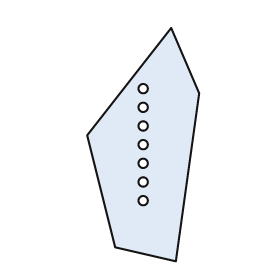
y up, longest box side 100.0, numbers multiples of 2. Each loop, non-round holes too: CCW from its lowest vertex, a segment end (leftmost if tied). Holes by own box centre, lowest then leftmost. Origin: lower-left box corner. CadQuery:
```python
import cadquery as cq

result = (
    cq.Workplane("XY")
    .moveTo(38.0, 0.0)
    .lineTo(48.0, 72.0)
    .lineTo(36.0, 100.0)
    .lineTo(0.0, 54.0)
    .lineTo(12.0, 6.0)
    .close()
    .moveTo(24.0, 26.0)
    .circle(2.0)
    .moveTo(24.0, 34.0)
    .circle(2.0)
    .moveTo(24.0, 42.0)
    .circle(2.0)
    .moveTo(24.0, 50.0)
    .circle(2.0)
    .moveTo(24.0, 58.0)
    .circle(2.0)
    .moveTo(24.0, 66.0)
    .circle(2.0)
    .moveTo(24.0, 74.0)
    .circle(2.0)
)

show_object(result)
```